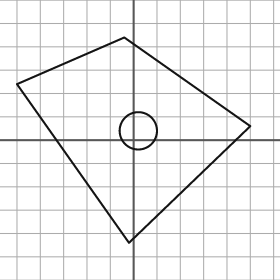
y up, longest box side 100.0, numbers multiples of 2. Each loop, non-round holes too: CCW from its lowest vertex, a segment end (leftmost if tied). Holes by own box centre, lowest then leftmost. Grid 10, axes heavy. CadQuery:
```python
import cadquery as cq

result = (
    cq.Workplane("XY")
    .moveTo(-2.0, -44.0)
    .lineTo(50.0, 6.0)
    .lineTo(-4.0, 44.0)
    .lineTo(-50.0, 24.0)
    .close()
    .moveTo(2.0, 4.0)
    .circle(8.0)
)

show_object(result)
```